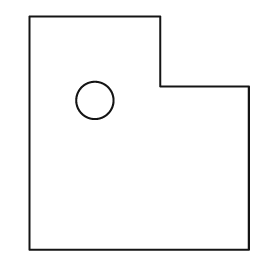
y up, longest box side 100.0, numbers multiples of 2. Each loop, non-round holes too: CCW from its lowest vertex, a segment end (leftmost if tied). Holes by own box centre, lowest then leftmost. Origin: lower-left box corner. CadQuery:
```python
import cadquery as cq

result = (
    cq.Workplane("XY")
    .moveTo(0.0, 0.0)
    .lineTo(94.0, 0.0)
    .lineTo(94.0, 70.0)
    .lineTo(56.0, 70.0)
    .lineTo(56.0, 100.0)
    .lineTo(0.0, 100.0)
    .close()
    .moveTo(28.0, 64.0)
    .circle(8.0)
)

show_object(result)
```